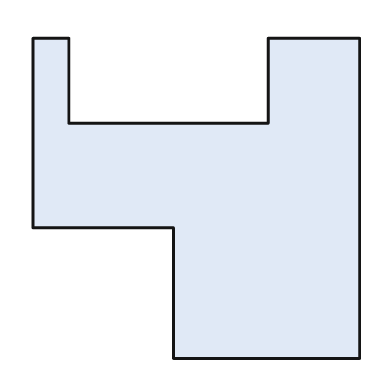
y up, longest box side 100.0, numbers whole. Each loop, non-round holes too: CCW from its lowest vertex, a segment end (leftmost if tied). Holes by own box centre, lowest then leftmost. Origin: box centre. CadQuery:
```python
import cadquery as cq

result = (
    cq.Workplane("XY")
    .moveTo(-7.0, -49.0)
    .lineTo(50.0, -49.0)
    .lineTo(50.0, 49.0)
    .lineTo(22.0, 49.0)
    .lineTo(22.0, 23.0)
    .lineTo(-39.0, 23.0)
    .lineTo(-39.0, 49.0)
    .lineTo(-50.0, 49.0)
    .lineTo(-50.0, -9.0)
    .lineTo(-7.0, -9.0)
    .close()
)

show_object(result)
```